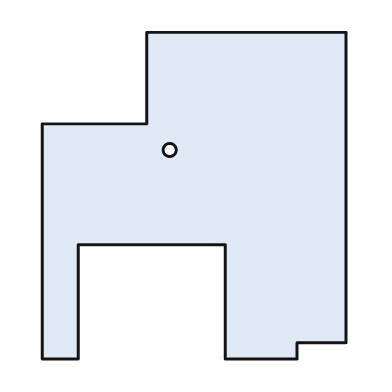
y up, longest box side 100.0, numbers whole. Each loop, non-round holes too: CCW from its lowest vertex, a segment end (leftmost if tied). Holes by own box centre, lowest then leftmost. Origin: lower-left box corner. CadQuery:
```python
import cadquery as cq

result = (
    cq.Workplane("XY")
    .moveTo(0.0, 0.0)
    .lineTo(11.0, 0.0)
    .lineTo(11.0, 35.0)
    .lineTo(56.0, 35.0)
    .lineTo(56.0, 0.0)
    .lineTo(78.0, 0.0)
    .lineTo(78.0, 5.0)
    .lineTo(93.0, 5.0)
    .lineTo(93.0, 100.0)
    .lineTo(32.0, 100.0)
    .lineTo(32.0, 72.0)
    .lineTo(0.0, 72.0)
    .close()
    .moveTo(39.0, 64.0)
    .circle(2.0)
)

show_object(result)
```